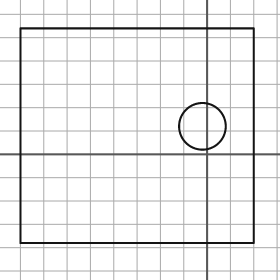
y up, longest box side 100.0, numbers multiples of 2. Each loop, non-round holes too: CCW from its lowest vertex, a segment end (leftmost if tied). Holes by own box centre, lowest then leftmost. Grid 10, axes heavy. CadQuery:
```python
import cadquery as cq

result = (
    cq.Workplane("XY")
    .moveTo(-80.0, -38.0)
    .lineTo(20.0, -38.0)
    .lineTo(20.0, 54.0)
    .lineTo(-80.0, 54.0)
    .close()
    .moveTo(-2.0, 12.0)
    .circle(10.0)
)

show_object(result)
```